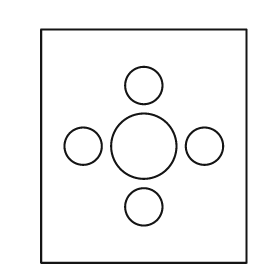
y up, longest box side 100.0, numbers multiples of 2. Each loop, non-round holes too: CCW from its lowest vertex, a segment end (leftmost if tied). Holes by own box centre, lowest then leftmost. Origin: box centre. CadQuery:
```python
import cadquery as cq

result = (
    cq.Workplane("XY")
    .moveTo(-44.0, -50.0)
    .lineTo(44.0, -50.0)
    .lineTo(44.0, 50.0)
    .lineTo(-44.0, 50.0)
    .close()
    .moveTo(0.0, -26.0)
    .circle(8.0)
    .moveTo(-26.0, 0.0)
    .circle(8.0)
    .moveTo(0.0, 0.0)
    .circle(14.0)
    .moveTo(26.0, 0.0)
    .circle(8.0)
    .moveTo(0.0, 26.0)
    .circle(8.0)
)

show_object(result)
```